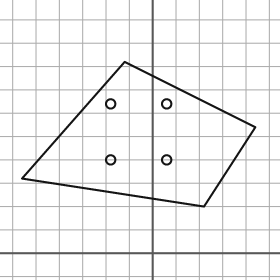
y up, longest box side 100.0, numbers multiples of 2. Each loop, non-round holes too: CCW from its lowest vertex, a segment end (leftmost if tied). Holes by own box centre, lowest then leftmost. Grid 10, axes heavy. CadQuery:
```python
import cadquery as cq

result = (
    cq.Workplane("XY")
    .moveTo(22.0, 20.0)
    .lineTo(44.0, 54.0)
    .lineTo(-12.0, 82.0)
    .lineTo(-56.0, 32.0)
    .close()
    .moveTo(-18.0, 40.0)
    .circle(2.0)
    .moveTo(6.0, 40.0)
    .circle(2.0)
    .moveTo(-18.0, 64.0)
    .circle(2.0)
    .moveTo(6.0, 64.0)
    .circle(2.0)
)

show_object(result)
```